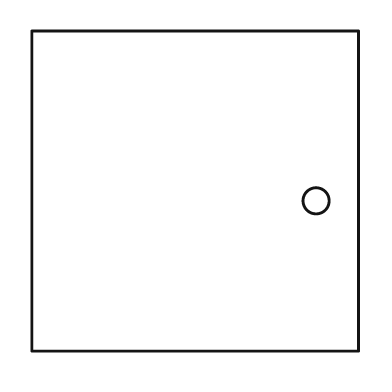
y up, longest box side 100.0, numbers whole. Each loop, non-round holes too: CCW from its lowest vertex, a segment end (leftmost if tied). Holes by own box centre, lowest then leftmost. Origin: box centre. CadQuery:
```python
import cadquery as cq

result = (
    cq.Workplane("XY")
    .moveTo(-50.0, -49.0)
    .lineTo(50.0, -49.0)
    .lineTo(50.0, 49.0)
    .lineTo(-50.0, 49.0)
    .close()
    .moveTo(37.0, -3.0)
    .circle(4.0)
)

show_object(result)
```